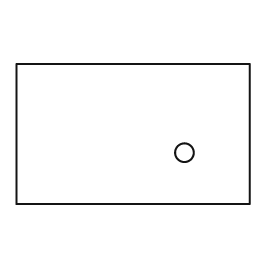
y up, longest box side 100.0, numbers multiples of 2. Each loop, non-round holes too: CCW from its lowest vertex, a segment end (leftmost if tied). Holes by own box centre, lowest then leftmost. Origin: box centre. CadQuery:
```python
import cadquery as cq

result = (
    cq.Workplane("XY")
    .moveTo(-50.0, -30.0)
    .lineTo(50.0, -30.0)
    .lineTo(50.0, 30.0)
    .lineTo(-50.0, 30.0)
    .close()
    .moveTo(22.0, -8.0)
    .circle(4.0)
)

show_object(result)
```